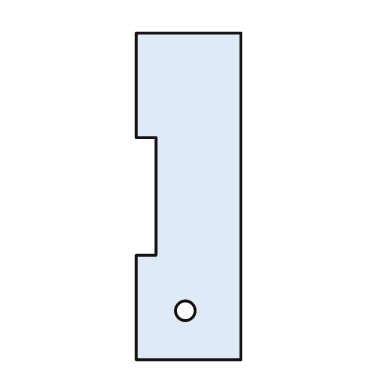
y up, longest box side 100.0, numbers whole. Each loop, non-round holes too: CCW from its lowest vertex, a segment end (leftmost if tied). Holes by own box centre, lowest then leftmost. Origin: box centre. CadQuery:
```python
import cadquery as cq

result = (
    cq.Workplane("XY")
    .moveTo(-16.0, -50.0)
    .lineTo(16.0, -50.0)
    .lineTo(16.0, 50.0)
    .lineTo(-16.0, 50.0)
    .lineTo(-16.0, 18.0)
    .lineTo(-10.0, 18.0)
    .lineTo(-10.0, -18.0)
    .lineTo(-16.0, -18.0)
    .close()
    .moveTo(-1.0, -35.0)
    .circle(3.0)
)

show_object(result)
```